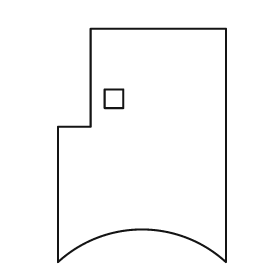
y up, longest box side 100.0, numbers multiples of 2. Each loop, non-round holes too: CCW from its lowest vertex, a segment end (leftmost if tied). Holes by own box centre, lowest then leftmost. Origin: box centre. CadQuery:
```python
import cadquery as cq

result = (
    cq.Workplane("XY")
    .moveTo(-36.0, -50.0)
    .threePointArc((0.0, -36.0), (36.0, -50.0))
    .lineTo(36.0, 50.0)
    .lineTo(-22.0, 50.0)
    .lineTo(-22.0, 8.0)
    .lineTo(-36.0, 8.0)
    .close()
    .moveTo(-16.0, 16.0)
    .lineTo(-8.0, 16.0)
    .lineTo(-8.0, 24.0)
    .lineTo(-16.0, 24.0)
    .close()
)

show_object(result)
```